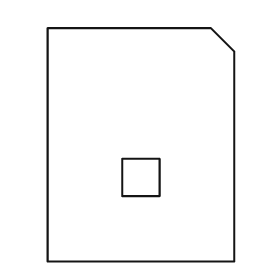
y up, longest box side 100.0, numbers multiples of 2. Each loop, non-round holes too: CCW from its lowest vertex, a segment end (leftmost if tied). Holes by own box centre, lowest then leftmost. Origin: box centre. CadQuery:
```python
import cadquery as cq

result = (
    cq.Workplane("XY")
    .moveTo(-40.0, -50.0)
    .lineTo(40.0, -50.0)
    .lineTo(40.0, 40.0)
    .lineTo(30.0, 50.0)
    .lineTo(-40.0, 50.0)
    .close()
    .moveTo(-8.0, -22.0)
    .lineTo(8.0, -22.0)
    .lineTo(8.0, -6.0)
    .lineTo(-8.0, -6.0)
    .close()
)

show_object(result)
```